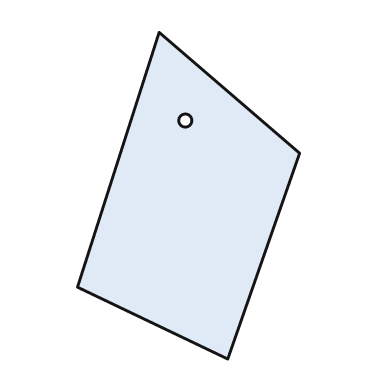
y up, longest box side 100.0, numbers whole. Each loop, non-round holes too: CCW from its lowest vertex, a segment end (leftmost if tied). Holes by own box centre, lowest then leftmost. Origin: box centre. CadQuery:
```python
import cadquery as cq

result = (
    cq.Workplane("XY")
    .moveTo(12.0, -50.0)
    .lineTo(34.0, 13.0)
    .lineTo(-9.0, 50.0)
    .lineTo(-34.0, -28.0)
    .close()
    .moveTo(-1.0, 23.0)
    .circle(2.0)
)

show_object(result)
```